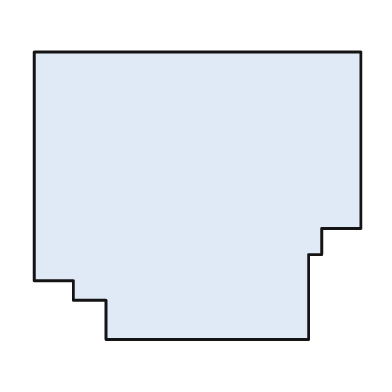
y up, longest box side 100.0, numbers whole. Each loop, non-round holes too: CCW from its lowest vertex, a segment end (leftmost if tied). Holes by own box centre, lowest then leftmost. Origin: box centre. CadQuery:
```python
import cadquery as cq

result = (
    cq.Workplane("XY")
    .moveTo(-28.0, -44.0)
    .lineTo(34.0, -44.0)
    .lineTo(34.0, -18.0)
    .lineTo(38.0, -18.0)
    .lineTo(38.0, -10.0)
    .lineTo(50.0, -10.0)
    .lineTo(50.0, 44.0)
    .lineTo(-50.0, 44.0)
    .lineTo(-50.0, -26.0)
    .lineTo(-38.0, -26.0)
    .lineTo(-38.0, -32.0)
    .lineTo(-28.0, -32.0)
    .close()
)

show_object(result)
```